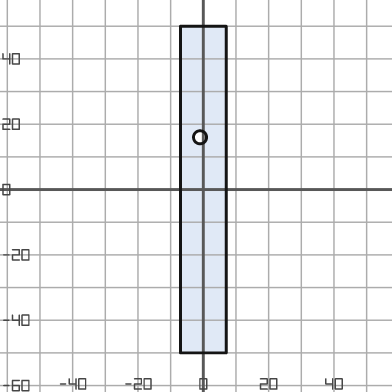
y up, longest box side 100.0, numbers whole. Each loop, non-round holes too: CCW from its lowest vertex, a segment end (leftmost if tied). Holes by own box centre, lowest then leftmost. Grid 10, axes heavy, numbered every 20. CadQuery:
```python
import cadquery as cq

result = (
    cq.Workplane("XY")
    .moveTo(-7.0, -50.0)
    .lineTo(7.0, -50.0)
    .lineTo(7.0, 50.0)
    .lineTo(-7.0, 50.0)
    .close()
    .moveTo(-1.0, 16.0)
    .circle(2.0)
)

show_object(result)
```